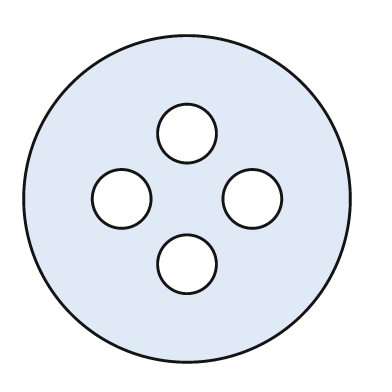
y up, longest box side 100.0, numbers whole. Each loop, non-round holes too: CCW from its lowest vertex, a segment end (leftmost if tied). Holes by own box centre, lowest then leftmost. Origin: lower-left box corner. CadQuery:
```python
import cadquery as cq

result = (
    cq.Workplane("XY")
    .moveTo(50.0, 50.0)
    .circle(50.0)
    .moveTo(50.0, 30.0)
    .circle(9.0)
    .moveTo(30.0, 50.0)
    .circle(9.0)
    .moveTo(70.0, 50.0)
    .circle(9.0)
    .moveTo(50.0, 70.0)
    .circle(9.0)
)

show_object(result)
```